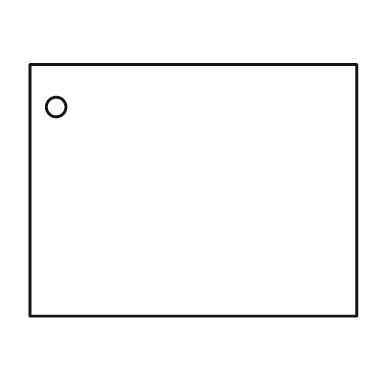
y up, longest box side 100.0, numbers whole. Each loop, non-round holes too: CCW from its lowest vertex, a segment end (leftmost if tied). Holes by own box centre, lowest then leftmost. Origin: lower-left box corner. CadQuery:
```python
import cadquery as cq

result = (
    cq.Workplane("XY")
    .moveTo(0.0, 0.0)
    .lineTo(100.0, 0.0)
    .lineTo(100.0, 77.0)
    .lineTo(0.0, 77.0)
    .close()
    .moveTo(8.0, 64.0)
    .circle(3.0)
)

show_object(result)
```